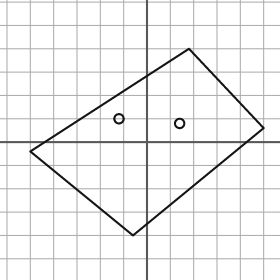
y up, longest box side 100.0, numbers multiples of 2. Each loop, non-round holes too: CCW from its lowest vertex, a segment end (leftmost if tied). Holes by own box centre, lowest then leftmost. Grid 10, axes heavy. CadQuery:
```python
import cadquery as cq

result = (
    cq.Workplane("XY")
    .moveTo(-6.0, -40.0)
    .lineTo(50.0, 6.0)
    .lineTo(18.0, 40.0)
    .lineTo(-50.0, -4.0)
    .close()
    .moveTo(14.0, 8.0)
    .circle(2.0)
    .moveTo(-12.0, 10.0)
    .circle(2.0)
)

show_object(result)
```